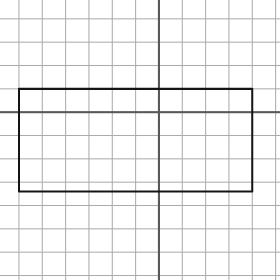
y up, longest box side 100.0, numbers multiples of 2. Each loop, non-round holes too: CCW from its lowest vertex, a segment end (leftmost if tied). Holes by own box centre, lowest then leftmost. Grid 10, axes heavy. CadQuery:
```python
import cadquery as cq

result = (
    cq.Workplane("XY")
    .moveTo(-60.0, -34.0)
    .lineTo(40.0, -34.0)
    .lineTo(40.0, 10.0)
    .lineTo(-60.0, 10.0)
    .close()
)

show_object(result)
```